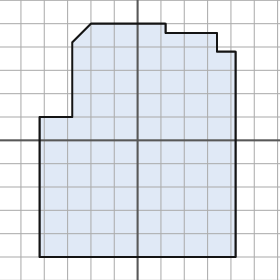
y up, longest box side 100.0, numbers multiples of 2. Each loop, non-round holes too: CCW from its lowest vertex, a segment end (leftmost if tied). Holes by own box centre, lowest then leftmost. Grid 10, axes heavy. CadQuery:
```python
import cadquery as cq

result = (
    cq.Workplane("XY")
    .moveTo(-42.0, -50.0)
    .lineTo(42.0, -50.0)
    .lineTo(42.0, 38.0)
    .lineTo(34.0, 38.0)
    .lineTo(34.0, 46.0)
    .lineTo(12.0, 46.0)
    .lineTo(12.0, 50.0)
    .lineTo(-20.0, 50.0)
    .lineTo(-28.0, 42.0)
    .lineTo(-28.0, 10.0)
    .lineTo(-42.0, 10.0)
    .close()
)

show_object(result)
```